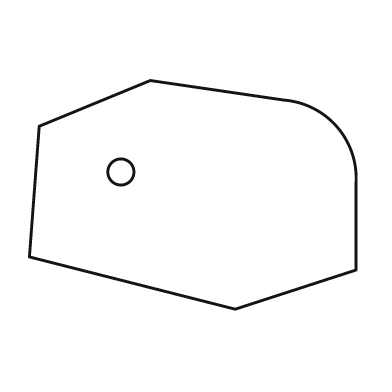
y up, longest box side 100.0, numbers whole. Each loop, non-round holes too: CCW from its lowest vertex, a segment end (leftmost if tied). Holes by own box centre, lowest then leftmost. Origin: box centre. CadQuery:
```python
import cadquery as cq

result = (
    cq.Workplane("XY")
    .moveTo(13.0, -35.0)
    .lineTo(50.0, -23.0)
    .lineTo(50.0, 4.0)
    .threePointArc((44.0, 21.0), (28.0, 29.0))
    .lineTo(-13.0, 35.0)
    .lineTo(-47.0, 21.0)
    .lineTo(-50.0, -19.0)
    .close()
    .moveTo(-22.0, 7.0)
    .circle(4.0)
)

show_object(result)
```